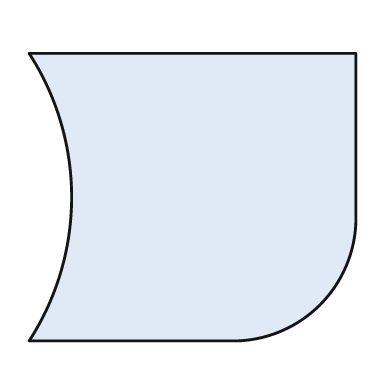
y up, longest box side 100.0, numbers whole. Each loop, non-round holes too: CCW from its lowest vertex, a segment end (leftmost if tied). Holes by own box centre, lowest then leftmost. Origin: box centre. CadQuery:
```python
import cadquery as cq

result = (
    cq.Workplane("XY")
    .moveTo(-50.0, -44.0)
    .lineTo(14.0, -44.0)
    .threePointArc((39.0, -33.0), (50.0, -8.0))
    .lineTo(50.0, 44.0)
    .lineTo(-50.0, 44.0)
    .threePointArc((-37.0, 0.0), (-50.0, -44.0))
    .close()
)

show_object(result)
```